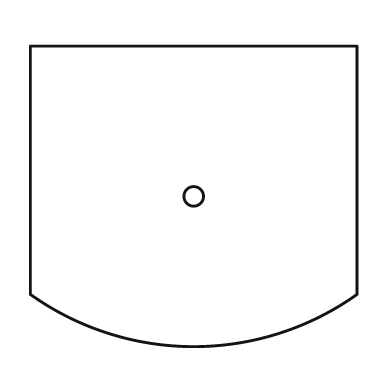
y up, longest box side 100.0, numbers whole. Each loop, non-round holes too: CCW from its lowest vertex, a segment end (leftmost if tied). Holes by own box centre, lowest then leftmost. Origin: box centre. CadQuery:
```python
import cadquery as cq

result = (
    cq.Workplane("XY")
    .moveTo(-50.0, -30.0)
    .threePointArc((0.0, -46.0), (50.0, -30.0))
    .lineTo(50.0, 46.0)
    .lineTo(-50.0, 46.0)
    .close()
    .moveTo(0.0, 0.0)
    .circle(3.0)
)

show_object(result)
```